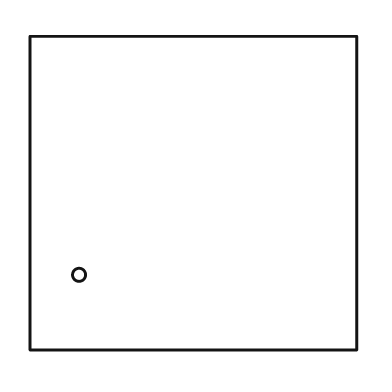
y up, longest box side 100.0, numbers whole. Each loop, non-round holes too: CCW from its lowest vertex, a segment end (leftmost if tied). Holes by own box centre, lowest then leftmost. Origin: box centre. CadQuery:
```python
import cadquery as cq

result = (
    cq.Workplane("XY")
    .moveTo(-50.0, -48.0)
    .lineTo(50.0, -48.0)
    .lineTo(50.0, 48.0)
    .lineTo(-50.0, 48.0)
    .close()
    .moveTo(-35.0, -25.0)
    .circle(2.0)
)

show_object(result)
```